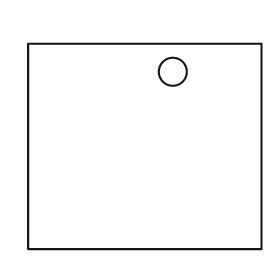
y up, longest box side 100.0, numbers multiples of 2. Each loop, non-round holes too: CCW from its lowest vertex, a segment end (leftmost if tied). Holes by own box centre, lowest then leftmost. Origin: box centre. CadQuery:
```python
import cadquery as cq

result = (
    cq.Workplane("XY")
    .moveTo(-50.0, -44.0)
    .lineTo(50.0, -44.0)
    .lineTo(50.0, 44.0)
    .lineTo(-50.0, 44.0)
    .close()
    .moveTo(12.0, 32.0)
    .circle(6.0)
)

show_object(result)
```